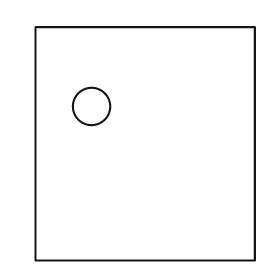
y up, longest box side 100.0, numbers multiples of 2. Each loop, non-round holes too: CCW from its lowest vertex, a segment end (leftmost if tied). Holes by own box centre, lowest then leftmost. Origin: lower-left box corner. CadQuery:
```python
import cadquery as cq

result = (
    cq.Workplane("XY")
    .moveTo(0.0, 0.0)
    .lineTo(94.0, 0.0)
    .lineTo(94.0, 100.0)
    .lineTo(0.0, 100.0)
    .close()
    .moveTo(24.0, 66.0)
    .circle(8.0)
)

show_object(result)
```